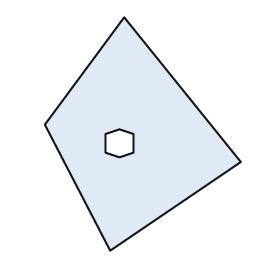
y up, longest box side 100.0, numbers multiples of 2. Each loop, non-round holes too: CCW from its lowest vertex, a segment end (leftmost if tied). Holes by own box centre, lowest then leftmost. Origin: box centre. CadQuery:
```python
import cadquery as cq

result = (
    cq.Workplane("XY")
    .moveTo(-14.0, -50.0)
    .lineTo(42.0, -12.0)
    .lineTo(-8.0, 50.0)
    .lineTo(-42.0, 4.0)
    .close()
    .moveTo(-10.0, -10.0)
    .lineTo(-4.0, -8.0)
    .lineTo(-4.0, 0.0)
    .lineTo(-10.0, 2.0)
    .lineTo(-16.0, 0.0)
    .lineTo(-16.0, -8.0)
    .close()
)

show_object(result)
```